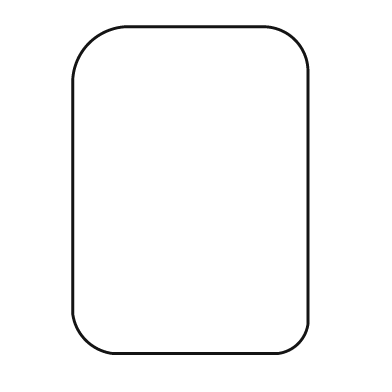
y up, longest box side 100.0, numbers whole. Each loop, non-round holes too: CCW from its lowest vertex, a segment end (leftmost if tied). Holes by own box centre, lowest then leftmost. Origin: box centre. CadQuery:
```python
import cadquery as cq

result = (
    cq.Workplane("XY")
    .moveTo(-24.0, -50.0)
    .lineTo(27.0, -50.0)
    .threePointArc((33.0, -47.0), (36.0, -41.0))
    .lineTo(36.0, 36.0)
    .threePointArc((32.0, 46.0), (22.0, 50.0))
    .lineTo(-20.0, 50.0)
    .threePointArc((-31.0, 45.0), (-36.0, 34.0))
    .lineTo(-36.0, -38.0)
    .threePointArc((-32.0, -46.0), (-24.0, -50.0))
    .close()
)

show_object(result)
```